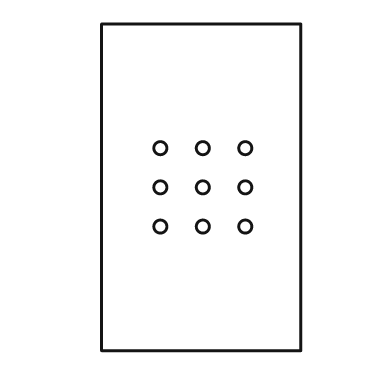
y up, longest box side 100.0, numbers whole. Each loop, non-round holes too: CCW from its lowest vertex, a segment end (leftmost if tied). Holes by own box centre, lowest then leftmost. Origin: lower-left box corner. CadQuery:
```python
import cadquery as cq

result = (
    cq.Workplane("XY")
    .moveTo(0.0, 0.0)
    .lineTo(61.0, 0.0)
    .lineTo(61.0, 100.0)
    .lineTo(0.0, 100.0)
    .close()
    .moveTo(18.0, 38.0)
    .circle(2.0)
    .moveTo(31.0, 38.0)
    .circle(2.0)
    .moveTo(44.0, 38.0)
    .circle(2.0)
    .moveTo(18.0, 50.0)
    .circle(2.0)
    .moveTo(31.0, 50.0)
    .circle(2.0)
    .moveTo(44.0, 50.0)
    .circle(2.0)
    .moveTo(18.0, 62.0)
    .circle(2.0)
    .moveTo(31.0, 62.0)
    .circle(2.0)
    .moveTo(44.0, 62.0)
    .circle(2.0)
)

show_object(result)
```